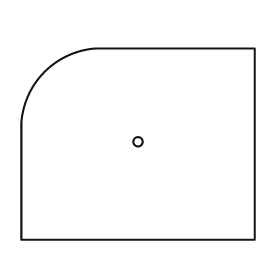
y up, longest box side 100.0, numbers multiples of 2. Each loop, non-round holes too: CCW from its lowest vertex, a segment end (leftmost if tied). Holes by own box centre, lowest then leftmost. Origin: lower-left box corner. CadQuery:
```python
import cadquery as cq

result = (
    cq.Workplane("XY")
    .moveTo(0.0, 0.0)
    .lineTo(100.0, 0.0)
    .lineTo(100.0, 82.0)
    .lineTo(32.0, 82.0)
    .threePointArc((10.0, 72.0), (0.0, 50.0))
    .close()
    .moveTo(50.0, 42.0)
    .circle(2.0)
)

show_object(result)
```